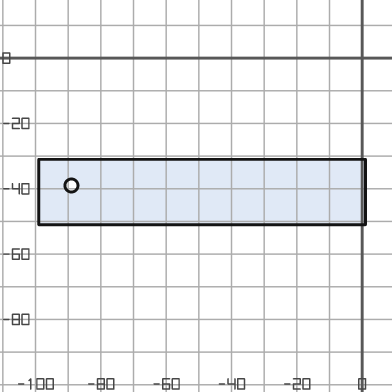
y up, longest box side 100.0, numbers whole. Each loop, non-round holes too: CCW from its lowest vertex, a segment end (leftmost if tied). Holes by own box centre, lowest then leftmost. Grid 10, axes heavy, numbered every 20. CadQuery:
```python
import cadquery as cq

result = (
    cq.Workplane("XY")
    .moveTo(-99.0, -51.0)
    .lineTo(1.0, -51.0)
    .lineTo(1.0, -31.0)
    .lineTo(-99.0, -31.0)
    .close()
    .moveTo(-89.0, -39.0)
    .circle(2.0)
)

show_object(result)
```